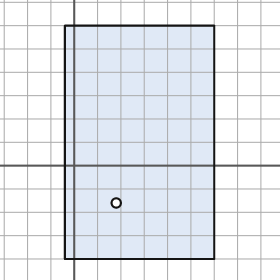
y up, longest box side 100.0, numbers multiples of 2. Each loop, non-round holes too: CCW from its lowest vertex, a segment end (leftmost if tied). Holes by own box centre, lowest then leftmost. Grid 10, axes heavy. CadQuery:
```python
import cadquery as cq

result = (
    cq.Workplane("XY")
    .moveTo(-4.0, -40.0)
    .lineTo(60.0, -40.0)
    .lineTo(60.0, 60.0)
    .lineTo(-4.0, 60.0)
    .close()
    .moveTo(18.0, -16.0)
    .circle(2.0)
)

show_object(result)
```